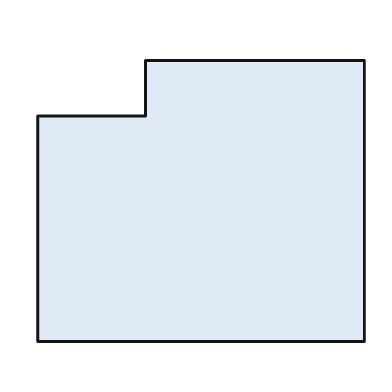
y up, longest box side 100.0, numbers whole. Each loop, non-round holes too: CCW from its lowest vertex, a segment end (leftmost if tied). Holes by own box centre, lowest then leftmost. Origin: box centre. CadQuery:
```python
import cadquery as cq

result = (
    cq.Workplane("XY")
    .moveTo(-50.0, -43.0)
    .lineTo(50.0, -43.0)
    .lineTo(50.0, 43.0)
    .lineTo(-17.0, 43.0)
    .lineTo(-17.0, 26.0)
    .lineTo(-50.0, 26.0)
    .close()
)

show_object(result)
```